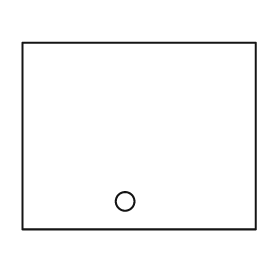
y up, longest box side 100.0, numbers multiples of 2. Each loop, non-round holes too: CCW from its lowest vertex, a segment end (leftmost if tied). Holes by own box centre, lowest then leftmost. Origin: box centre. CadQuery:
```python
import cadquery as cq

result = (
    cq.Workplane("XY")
    .moveTo(-50.0, -40.0)
    .lineTo(50.0, -40.0)
    .lineTo(50.0, 40.0)
    .lineTo(-50.0, 40.0)
    .close()
    .moveTo(-6.0, -28.0)
    .circle(4.0)
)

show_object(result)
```